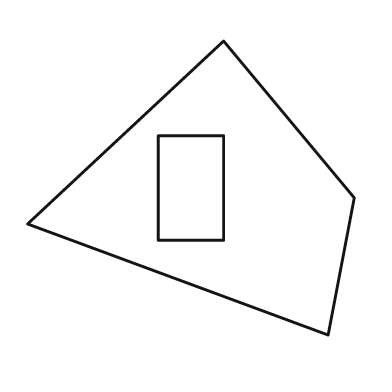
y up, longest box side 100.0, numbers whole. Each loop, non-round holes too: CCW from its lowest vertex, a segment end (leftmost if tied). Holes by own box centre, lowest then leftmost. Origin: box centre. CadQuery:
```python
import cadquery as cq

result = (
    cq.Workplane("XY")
    .moveTo(42.0, -45.0)
    .lineTo(50.0, -3.0)
    .lineTo(10.0, 45.0)
    .lineTo(-50.0, -11.0)
    .close()
    .moveTo(-10.0, -16.0)
    .lineTo(10.0, -16.0)
    .lineTo(10.0, 16.0)
    .lineTo(-10.0, 16.0)
    .close()
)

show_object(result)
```